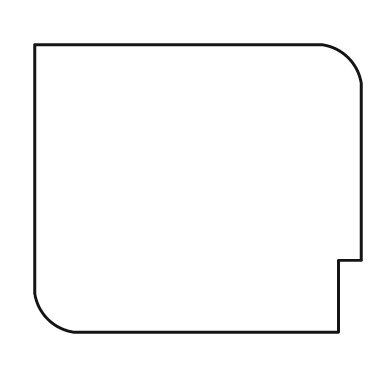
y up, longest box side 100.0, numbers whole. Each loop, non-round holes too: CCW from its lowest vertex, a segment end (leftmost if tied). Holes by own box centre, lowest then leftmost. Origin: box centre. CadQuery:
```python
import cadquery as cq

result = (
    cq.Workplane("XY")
    .moveTo(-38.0, -44.0)
    .lineTo(43.0, -44.0)
    .lineTo(43.0, -22.0)
    .lineTo(50.0, -22.0)
    .lineTo(50.0, 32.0)
    .threePointArc((46.0, 40.0), (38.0, 44.0))
    .lineTo(-50.0, 44.0)
    .lineTo(-50.0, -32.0)
    .threePointArc((-46.0, -40.0), (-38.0, -44.0))
    .close()
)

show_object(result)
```